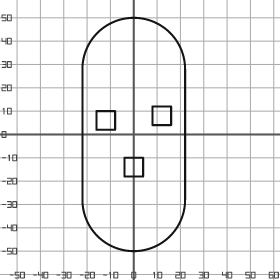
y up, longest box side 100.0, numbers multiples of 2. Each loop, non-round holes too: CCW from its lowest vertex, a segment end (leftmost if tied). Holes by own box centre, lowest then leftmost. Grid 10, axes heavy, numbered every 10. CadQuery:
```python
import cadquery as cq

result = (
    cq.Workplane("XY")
    .moveTo(-22.0, -28.0)
    .threePointArc((0.0, -50.0), (22.0, -28.0))
    .lineTo(22.0, 28.0)
    .threePointArc((0.0, 50.0), (-22.0, 28.0))
    .close()
    .moveTo(-4.0, -18.0)
    .lineTo(4.0, -18.0)
    .lineTo(4.0, -10.0)
    .lineTo(-4.0, -10.0)
    .close()
    .moveTo(-16.0, 2.0)
    .lineTo(-8.0, 2.0)
    .lineTo(-8.0, 10.0)
    .lineTo(-16.0, 10.0)
    .close()
    .moveTo(8.0, 4.0)
    .lineTo(16.0, 4.0)
    .lineTo(16.0, 12.0)
    .lineTo(8.0, 12.0)
    .close()
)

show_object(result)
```